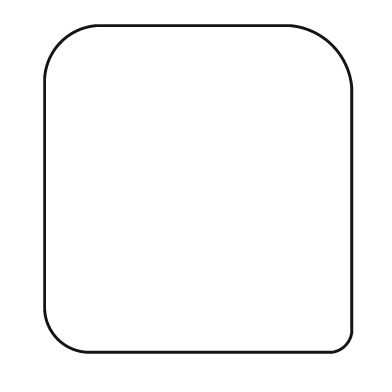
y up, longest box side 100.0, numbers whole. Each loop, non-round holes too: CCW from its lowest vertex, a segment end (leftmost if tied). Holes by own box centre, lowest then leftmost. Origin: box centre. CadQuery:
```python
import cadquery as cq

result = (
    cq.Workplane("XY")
    .moveTo(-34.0, -50.0)
    .lineTo(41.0, -50.0)
    .threePointArc((45.0, -48.0), (47.0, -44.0))
    .lineTo(47.0, 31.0)
    .threePointArc((41.0, 44.0), (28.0, 50.0))
    .lineTo(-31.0, 50.0)
    .threePointArc((-42.0, 45.0), (-47.0, 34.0))
    .lineTo(-47.0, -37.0)
    .threePointArc((-43.0, -46.0), (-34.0, -50.0))
    .close()
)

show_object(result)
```